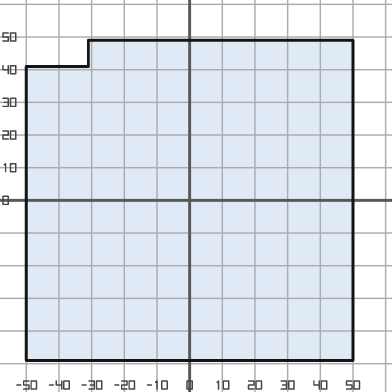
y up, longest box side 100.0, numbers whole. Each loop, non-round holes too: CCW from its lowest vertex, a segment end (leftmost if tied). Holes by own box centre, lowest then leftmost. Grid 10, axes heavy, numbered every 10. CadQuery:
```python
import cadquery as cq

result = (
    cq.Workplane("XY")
    .moveTo(-50.0, -49.0)
    .lineTo(50.0, -49.0)
    .lineTo(50.0, 49.0)
    .lineTo(-31.0, 49.0)
    .lineTo(-31.0, 41.0)
    .lineTo(-50.0, 41.0)
    .close()
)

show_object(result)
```